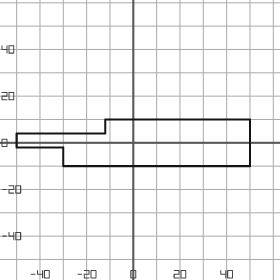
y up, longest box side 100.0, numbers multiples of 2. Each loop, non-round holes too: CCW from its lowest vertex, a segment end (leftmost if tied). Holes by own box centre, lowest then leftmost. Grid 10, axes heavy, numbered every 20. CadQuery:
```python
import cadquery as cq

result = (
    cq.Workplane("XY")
    .moveTo(-30.0, -10.0)
    .lineTo(50.0, -10.0)
    .lineTo(50.0, 10.0)
    .lineTo(-12.0, 10.0)
    .lineTo(-12.0, 4.0)
    .lineTo(-50.0, 4.0)
    .lineTo(-50.0, -2.0)
    .lineTo(-30.0, -2.0)
    .close()
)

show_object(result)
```